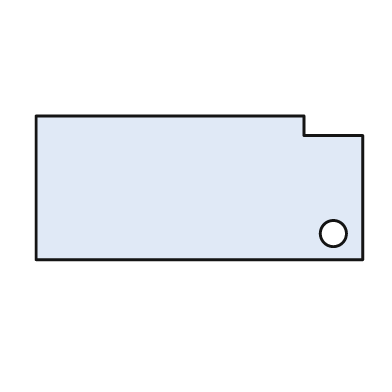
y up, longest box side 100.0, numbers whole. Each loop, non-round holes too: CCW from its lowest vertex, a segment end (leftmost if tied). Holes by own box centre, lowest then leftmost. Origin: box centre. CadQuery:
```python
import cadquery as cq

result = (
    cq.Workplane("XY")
    .moveTo(-50.0, -22.0)
    .lineTo(50.0, -22.0)
    .lineTo(50.0, 16.0)
    .lineTo(32.0, 16.0)
    .lineTo(32.0, 22.0)
    .lineTo(-50.0, 22.0)
    .close()
    .moveTo(41.0, -14.0)
    .circle(4.0)
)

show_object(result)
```